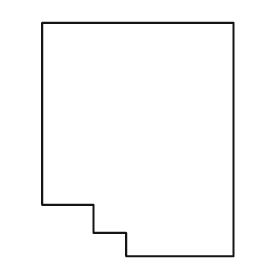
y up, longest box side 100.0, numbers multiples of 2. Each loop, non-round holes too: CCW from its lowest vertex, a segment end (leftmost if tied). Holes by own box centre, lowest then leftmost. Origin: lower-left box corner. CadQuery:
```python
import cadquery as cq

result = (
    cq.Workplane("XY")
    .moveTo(36.0, 0.0)
    .lineTo(82.0, 0.0)
    .lineTo(82.0, 100.0)
    .lineTo(0.0, 100.0)
    .lineTo(0.0, 22.0)
    .lineTo(22.0, 22.0)
    .lineTo(22.0, 10.0)
    .lineTo(36.0, 10.0)
    .close()
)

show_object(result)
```